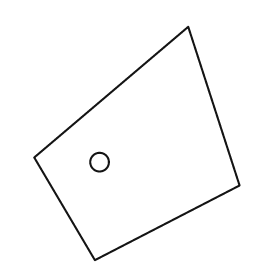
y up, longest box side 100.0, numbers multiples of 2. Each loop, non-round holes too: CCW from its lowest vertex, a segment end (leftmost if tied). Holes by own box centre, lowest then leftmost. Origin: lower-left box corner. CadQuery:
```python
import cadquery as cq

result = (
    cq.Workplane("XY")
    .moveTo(26.0, 0.0)
    .lineTo(88.0, 32.0)
    .lineTo(66.0, 100.0)
    .lineTo(0.0, 44.0)
    .close()
    .moveTo(28.0, 42.0)
    .circle(4.0)
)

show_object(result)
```